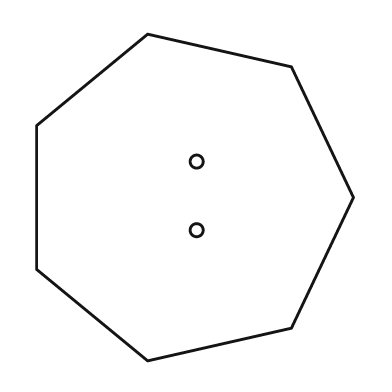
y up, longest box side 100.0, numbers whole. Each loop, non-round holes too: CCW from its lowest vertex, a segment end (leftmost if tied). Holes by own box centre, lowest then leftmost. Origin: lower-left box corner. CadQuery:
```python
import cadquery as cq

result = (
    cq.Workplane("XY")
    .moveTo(34.0, 0.0)
    .lineTo(78.0, 10.0)
    .lineTo(97.0, 50.0)
    .lineTo(78.0, 90.0)
    .lineTo(34.0, 100.0)
    .lineTo(0.0, 72.0)
    .lineTo(0.0, 28.0)
    .close()
    .moveTo(49.0, 40.0)
    .circle(2.0)
    .moveTo(49.0, 61.0)
    .circle(2.0)
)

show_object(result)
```